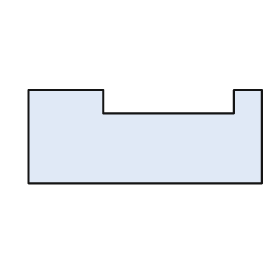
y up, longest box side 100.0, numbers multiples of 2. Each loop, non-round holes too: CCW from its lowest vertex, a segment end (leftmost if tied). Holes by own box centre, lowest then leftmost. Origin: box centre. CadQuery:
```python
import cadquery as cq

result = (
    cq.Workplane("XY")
    .moveTo(-50.0, -20.0)
    .lineTo(50.0, -20.0)
    .lineTo(50.0, 20.0)
    .lineTo(38.0, 20.0)
    .lineTo(38.0, 10.0)
    .lineTo(-18.0, 10.0)
    .lineTo(-18.0, 20.0)
    .lineTo(-50.0, 20.0)
    .close()
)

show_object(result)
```